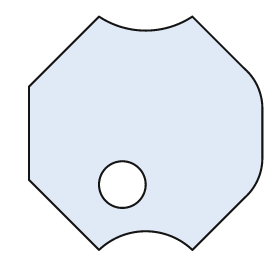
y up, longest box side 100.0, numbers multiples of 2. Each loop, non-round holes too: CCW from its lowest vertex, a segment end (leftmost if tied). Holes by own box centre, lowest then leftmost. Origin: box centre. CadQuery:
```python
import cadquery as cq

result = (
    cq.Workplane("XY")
    .moveTo(-20.0, -50.0)
    .threePointArc((0.0, -42.0), (20.0, -50.0))
    .lineTo(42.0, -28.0)
    .threePointArc((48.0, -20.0), (50.0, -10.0))
    .lineTo(50.0, 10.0)
    .threePointArc((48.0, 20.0), (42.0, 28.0))
    .lineTo(20.0, 50.0)
    .threePointArc((0.0, 44.0), (-20.0, 50.0))
    .lineTo(-50.0, 20.0)
    .lineTo(-50.0, -20.0)
    .close()
    .moveTo(-10.0, -22.0)
    .circle(10.0)
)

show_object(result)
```